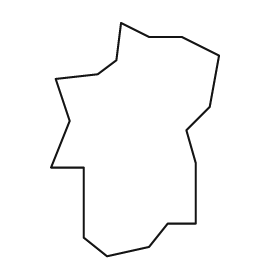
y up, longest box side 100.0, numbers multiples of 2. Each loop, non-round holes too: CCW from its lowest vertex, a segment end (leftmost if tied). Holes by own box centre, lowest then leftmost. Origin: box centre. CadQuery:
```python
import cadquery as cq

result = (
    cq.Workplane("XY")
    .moveTo(-12.0, -50.0)
    .lineTo(6.0, -46.0)
    .lineTo(14.0, -36.0)
    .lineTo(26.0, -36.0)
    .lineTo(26.0, -10.0)
    .lineTo(22.0, 4.0)
    .lineTo(32.0, 14.0)
    .lineTo(36.0, 36.0)
    .lineTo(20.0, 44.0)
    .lineTo(6.0, 44.0)
    .lineTo(-6.0, 50.0)
    .lineTo(-8.0, 34.0)
    .lineTo(-16.0, 28.0)
    .lineTo(-34.0, 26.0)
    .lineTo(-28.0, 8.0)
    .lineTo(-36.0, -12.0)
    .lineTo(-22.0, -12.0)
    .lineTo(-22.0, -42.0)
    .close()
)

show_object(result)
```